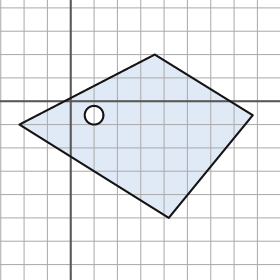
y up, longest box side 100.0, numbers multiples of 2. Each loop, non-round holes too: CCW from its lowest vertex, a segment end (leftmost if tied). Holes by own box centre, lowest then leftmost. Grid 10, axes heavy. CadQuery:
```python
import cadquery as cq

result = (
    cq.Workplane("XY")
    .moveTo(42.0, -50.0)
    .lineTo(78.0, -6.0)
    .lineTo(36.0, 20.0)
    .lineTo(-22.0, -10.0)
    .close()
    .moveTo(10.0, -6.0)
    .circle(4.0)
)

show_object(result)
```